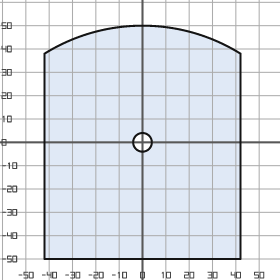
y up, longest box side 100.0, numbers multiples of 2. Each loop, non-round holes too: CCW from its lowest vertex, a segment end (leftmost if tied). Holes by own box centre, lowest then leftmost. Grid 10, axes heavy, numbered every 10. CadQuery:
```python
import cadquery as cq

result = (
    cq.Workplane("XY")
    .moveTo(-42.0, -50.0)
    .lineTo(42.0, -50.0)
    .lineTo(42.0, 38.0)
    .threePointArc((0.0, 50.0), (-42.0, 38.0))
    .close()
    .moveTo(0.0, 0.0)
    .circle(4.0)
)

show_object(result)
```